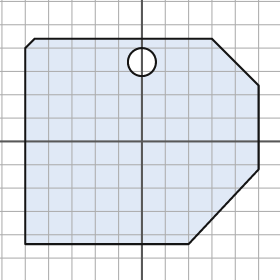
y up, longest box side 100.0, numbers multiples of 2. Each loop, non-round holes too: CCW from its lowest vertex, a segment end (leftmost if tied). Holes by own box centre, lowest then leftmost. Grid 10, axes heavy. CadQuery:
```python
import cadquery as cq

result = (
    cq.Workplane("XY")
    .moveTo(-50.0, -44.0)
    .lineTo(20.0, -44.0)
    .lineTo(50.0, -12.0)
    .lineTo(50.0, 24.0)
    .lineTo(30.0, 44.0)
    .lineTo(-46.0, 44.0)
    .lineTo(-50.0, 40.0)
    .close()
    .moveTo(0.0, 34.0)
    .circle(6.0)
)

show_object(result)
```